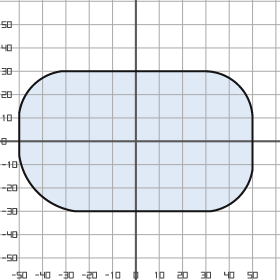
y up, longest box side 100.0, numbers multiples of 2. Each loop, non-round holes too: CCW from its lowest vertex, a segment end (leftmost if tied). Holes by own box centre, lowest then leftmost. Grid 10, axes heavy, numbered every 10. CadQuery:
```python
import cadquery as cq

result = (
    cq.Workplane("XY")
    .moveTo(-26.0, -30.0)
    .lineTo(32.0, -30.0)
    .threePointArc((44.0, -24.0), (50.0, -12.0))
    .lineTo(50.0, 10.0)
    .threePointArc((44.0, 24.0), (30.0, 30.0))
    .lineTo(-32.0, 30.0)
    .threePointArc((-44.0, 24.0), (-50.0, 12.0))
    .lineTo(-50.0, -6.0)
    .threePointArc((-42.0, -22.0), (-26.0, -30.0))
    .close()
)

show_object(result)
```